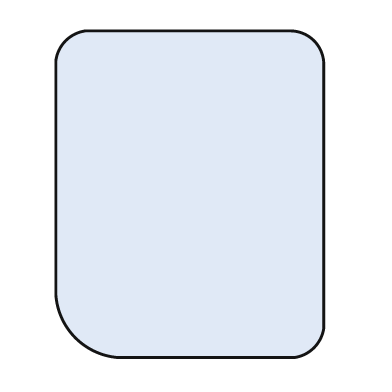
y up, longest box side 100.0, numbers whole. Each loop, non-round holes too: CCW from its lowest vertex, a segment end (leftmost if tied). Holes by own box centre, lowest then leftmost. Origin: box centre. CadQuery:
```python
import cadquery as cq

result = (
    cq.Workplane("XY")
    .moveTo(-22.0, -50.0)
    .lineTo(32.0, -50.0)
    .threePointArc((38.0, -47.0), (41.0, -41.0))
    .lineTo(41.0, 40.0)
    .threePointArc((38.0, 47.0), (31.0, 50.0))
    .lineTo(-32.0, 50.0)
    .threePointArc((-38.0, 47.0), (-41.0, 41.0))
    .lineTo(-41.0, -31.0)
    .threePointArc((-35.0, -44.0), (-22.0, -50.0))
    .close()
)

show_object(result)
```